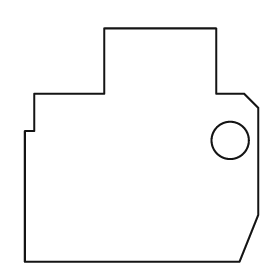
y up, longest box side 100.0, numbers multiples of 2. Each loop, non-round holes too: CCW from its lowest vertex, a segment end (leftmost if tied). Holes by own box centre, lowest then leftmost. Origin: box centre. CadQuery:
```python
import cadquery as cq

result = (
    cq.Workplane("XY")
    .moveTo(-50.0, -50.0)
    .lineTo(42.0, -50.0)
    .lineTo(50.0, -30.0)
    .lineTo(50.0, 16.0)
    .lineTo(44.0, 22.0)
    .lineTo(32.0, 22.0)
    .lineTo(32.0, 50.0)
    .lineTo(-16.0, 50.0)
    .lineTo(-16.0, 22.0)
    .lineTo(-46.0, 22.0)
    .lineTo(-46.0, 6.0)
    .lineTo(-50.0, 6.0)
    .close()
    .moveTo(38.0, 2.0)
    .circle(8.0)
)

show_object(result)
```